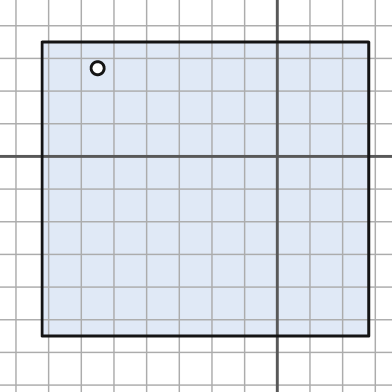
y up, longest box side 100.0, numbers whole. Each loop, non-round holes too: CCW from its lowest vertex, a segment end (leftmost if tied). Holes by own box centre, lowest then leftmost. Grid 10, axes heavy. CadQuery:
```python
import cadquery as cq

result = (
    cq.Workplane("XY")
    .moveTo(-72.0, -55.0)
    .lineTo(28.0, -55.0)
    .lineTo(28.0, 35.0)
    .lineTo(-72.0, 35.0)
    .close()
    .moveTo(-55.0, 27.0)
    .circle(2.0)
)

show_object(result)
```